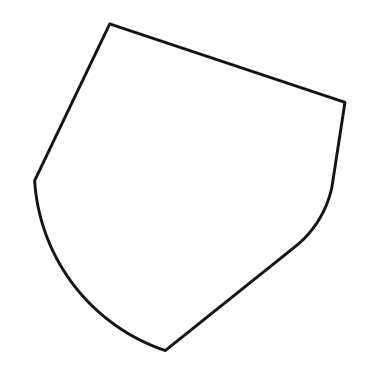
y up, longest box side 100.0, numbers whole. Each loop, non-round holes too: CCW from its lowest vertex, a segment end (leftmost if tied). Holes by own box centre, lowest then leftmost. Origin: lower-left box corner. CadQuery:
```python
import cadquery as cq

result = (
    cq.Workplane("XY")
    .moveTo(40.0, 0.0)
    .lineTo(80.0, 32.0)
    .threePointArc((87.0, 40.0), (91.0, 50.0))
    .lineTo(95.0, 76.0)
    .lineTo(23.0, 100.0)
    .lineTo(0.0, 52.0)
    .threePointArc((12.0, 20.0), (40.0, 0.0))
    .close()
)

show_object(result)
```